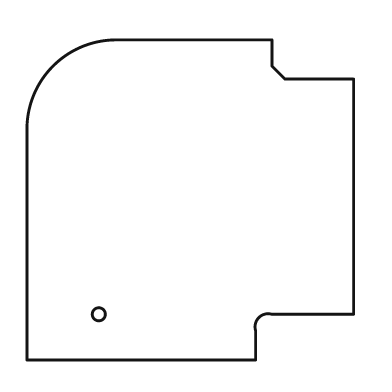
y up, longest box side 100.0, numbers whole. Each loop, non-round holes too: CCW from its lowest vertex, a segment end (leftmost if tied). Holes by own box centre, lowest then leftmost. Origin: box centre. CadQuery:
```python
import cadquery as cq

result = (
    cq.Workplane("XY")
    .moveTo(-50.0, -49.0)
    .lineTo(20.0, -49.0)
    .lineTo(20.0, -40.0)
    .threePointArc((21.0, -36.0), (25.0, -35.0))
    .lineTo(50.0, -35.0)
    .lineTo(50.0, 37.0)
    .lineTo(29.0, 37.0)
    .lineTo(25.0, 41.0)
    .lineTo(25.0, 49.0)
    .lineTo(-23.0, 49.0)
    .threePointArc((-42.0, 41.0), (-50.0, 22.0))
    .close()
    .moveTo(-28.0, -35.0)
    .circle(2.0)
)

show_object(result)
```